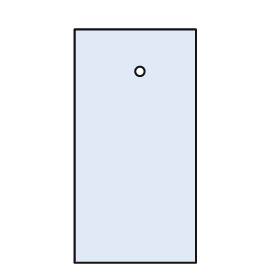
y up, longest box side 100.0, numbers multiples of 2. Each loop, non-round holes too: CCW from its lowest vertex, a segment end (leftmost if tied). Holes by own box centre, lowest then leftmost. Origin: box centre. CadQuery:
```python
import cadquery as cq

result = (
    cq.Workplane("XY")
    .moveTo(-26.0, -50.0)
    .lineTo(26.0, -50.0)
    .lineTo(26.0, 50.0)
    .lineTo(-26.0, 50.0)
    .close()
    .moveTo(2.0, 32.0)
    .circle(2.0)
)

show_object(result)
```